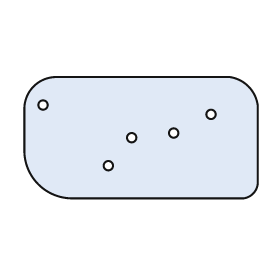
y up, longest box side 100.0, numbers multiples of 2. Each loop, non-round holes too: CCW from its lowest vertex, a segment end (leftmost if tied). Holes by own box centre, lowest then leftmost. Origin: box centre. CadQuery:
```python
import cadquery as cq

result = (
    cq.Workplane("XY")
    .moveTo(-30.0, -26.0)
    .lineTo(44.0, -26.0)
    .threePointArc((48.0, -24.0), (50.0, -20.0))
    .lineTo(50.0, 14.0)
    .threePointArc((46.0, 22.0), (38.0, 26.0))
    .lineTo(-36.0, 26.0)
    .threePointArc((-46.0, 22.0), (-50.0, 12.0))
    .lineTo(-50.0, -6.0)
    .threePointArc((-44.0, -20.0), (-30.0, -26.0))
    .close()
    .moveTo(-14.0, -12.0)
    .circle(2.0)
    .moveTo(-4.0, 0.0)
    .circle(2.0)
    .moveTo(14.0, 2.0)
    .circle(2.0)
    .moveTo(30.0, 10.0)
    .circle(2.0)
    .moveTo(-42.0, 14.0)
    .circle(2.0)
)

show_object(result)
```